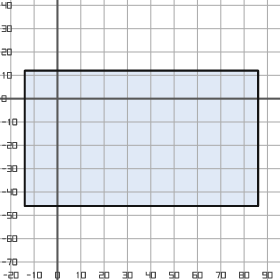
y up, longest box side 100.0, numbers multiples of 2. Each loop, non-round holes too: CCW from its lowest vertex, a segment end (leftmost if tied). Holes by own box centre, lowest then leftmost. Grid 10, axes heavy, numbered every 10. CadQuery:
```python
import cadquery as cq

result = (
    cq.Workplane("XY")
    .moveTo(-14.0, -46.0)
    .lineTo(86.0, -46.0)
    .lineTo(86.0, 12.0)
    .lineTo(-14.0, 12.0)
    .close()
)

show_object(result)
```